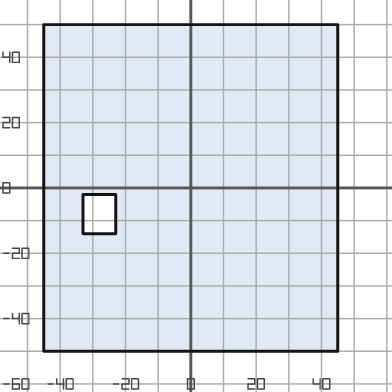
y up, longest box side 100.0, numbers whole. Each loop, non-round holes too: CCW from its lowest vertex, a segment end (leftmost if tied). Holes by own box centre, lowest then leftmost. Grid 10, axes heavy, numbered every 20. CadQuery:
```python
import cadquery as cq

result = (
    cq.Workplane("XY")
    .moveTo(-45.0, -50.0)
    .lineTo(45.0, -50.0)
    .lineTo(45.0, 50.0)
    .lineTo(-45.0, 50.0)
    .close()
    .moveTo(-33.0, -14.0)
    .lineTo(-23.0, -14.0)
    .lineTo(-23.0, -2.0)
    .lineTo(-33.0, -2.0)
    .close()
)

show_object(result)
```